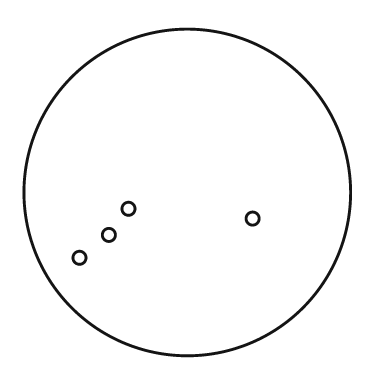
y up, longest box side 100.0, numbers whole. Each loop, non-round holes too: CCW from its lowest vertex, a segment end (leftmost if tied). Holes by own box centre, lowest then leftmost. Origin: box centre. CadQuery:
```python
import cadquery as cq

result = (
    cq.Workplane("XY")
    .moveTo(0.0, 0.0)
    .circle(50.0)
    .moveTo(-33.0, -20.0)
    .circle(2.0)
    .moveTo(-24.0, -13.0)
    .circle(2.0)
    .moveTo(20.0, -8.0)
    .circle(2.0)
    .moveTo(-18.0, -5.0)
    .circle(2.0)
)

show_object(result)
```